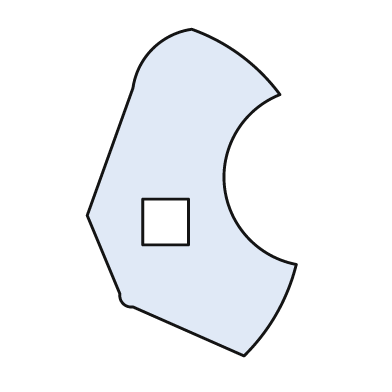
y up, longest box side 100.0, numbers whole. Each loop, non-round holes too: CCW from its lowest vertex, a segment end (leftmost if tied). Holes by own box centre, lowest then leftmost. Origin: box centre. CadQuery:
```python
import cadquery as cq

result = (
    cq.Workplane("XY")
    .moveTo(16.0, -50.0)
    .threePointArc((26.0, -37.0), (32.0, -22.0))
    .threePointArc((10.0, 2.0), (27.0, 30.0))
    .threePointArc((15.0, 42.0), (0.0, 50.0))
    .threePointArc((-12.0, 44.0), (-18.0, 32.0))
    .lineTo(-32.0, -7.0)
    .lineTo(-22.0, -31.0)
    .threePointArc((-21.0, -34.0), (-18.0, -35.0))
    .close()
    .moveTo(-15.0, -16.0)
    .lineTo(-1.0, -16.0)
    .lineTo(-1.0, -2.0)
    .lineTo(-15.0, -2.0)
    .close()
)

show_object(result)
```